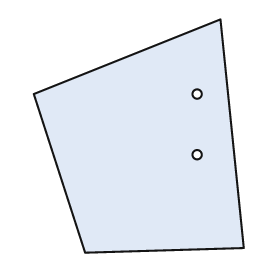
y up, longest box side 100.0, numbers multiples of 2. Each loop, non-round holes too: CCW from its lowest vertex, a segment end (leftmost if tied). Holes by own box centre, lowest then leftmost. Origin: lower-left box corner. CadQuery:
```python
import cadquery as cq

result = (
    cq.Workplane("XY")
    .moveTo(22.0, 0.0)
    .lineTo(90.0, 2.0)
    .lineTo(80.0, 100.0)
    .lineTo(0.0, 68.0)
    .close()
    .moveTo(70.0, 42.0)
    .circle(2.0)
    .moveTo(70.0, 68.0)
    .circle(2.0)
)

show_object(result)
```